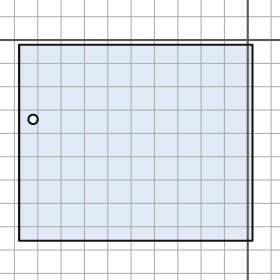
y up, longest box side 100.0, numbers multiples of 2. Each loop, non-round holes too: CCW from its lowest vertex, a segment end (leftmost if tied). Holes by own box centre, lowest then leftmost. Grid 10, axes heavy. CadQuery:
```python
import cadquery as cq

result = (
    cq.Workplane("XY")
    .moveTo(-98.0, -86.0)
    .lineTo(2.0, -86.0)
    .lineTo(2.0, -2.0)
    .lineTo(-98.0, -2.0)
    .close()
    .moveTo(-92.0, -34.0)
    .circle(2.0)
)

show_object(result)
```